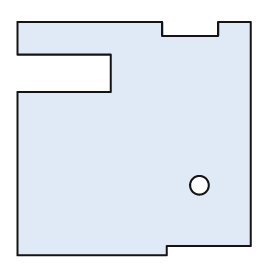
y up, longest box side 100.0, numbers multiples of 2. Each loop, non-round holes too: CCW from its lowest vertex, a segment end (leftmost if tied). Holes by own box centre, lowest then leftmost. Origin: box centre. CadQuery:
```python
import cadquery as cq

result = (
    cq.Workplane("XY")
    .moveTo(-50.0, -50.0)
    .lineTo(14.0, -50.0)
    .lineTo(14.0, -46.0)
    .lineTo(50.0, -46.0)
    .lineTo(50.0, 50.0)
    .lineTo(36.0, 50.0)
    .lineTo(36.0, 44.0)
    .lineTo(12.0, 44.0)
    .lineTo(12.0, 50.0)
    .lineTo(-50.0, 50.0)
    .lineTo(-50.0, 36.0)
    .lineTo(-10.0, 36.0)
    .lineTo(-10.0, 20.0)
    .lineTo(-50.0, 20.0)
    .close()
    .moveTo(28.0, -20.0)
    .circle(4.0)
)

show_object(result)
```